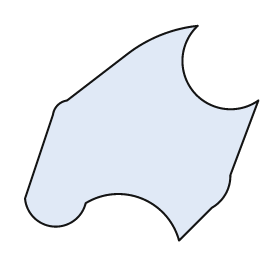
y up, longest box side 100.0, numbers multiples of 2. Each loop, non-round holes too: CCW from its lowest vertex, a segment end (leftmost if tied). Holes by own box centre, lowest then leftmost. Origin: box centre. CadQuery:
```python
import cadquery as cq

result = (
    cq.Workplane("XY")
    .moveTo(16.0, -46.0)
    .lineTo(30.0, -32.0)
    .threePointArc((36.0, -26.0), (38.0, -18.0))
    .lineTo(50.0, 14.0)
    .threePointArc((22.0, 18.0), (24.0, 46.0))
    .threePointArc((8.0, 42.0), (-6.0, 34.0))
    .lineTo(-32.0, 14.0)
    .threePointArc((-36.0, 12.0), (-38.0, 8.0))
    .lineTo(-50.0, -28.0)
    .threePointArc((-38.0, -40.0), (-24.0, -30.0))
    .threePointArc((0.0, -28.0), (16.0, -46.0))
    .close()
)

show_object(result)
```